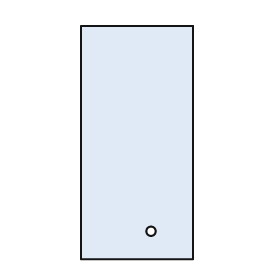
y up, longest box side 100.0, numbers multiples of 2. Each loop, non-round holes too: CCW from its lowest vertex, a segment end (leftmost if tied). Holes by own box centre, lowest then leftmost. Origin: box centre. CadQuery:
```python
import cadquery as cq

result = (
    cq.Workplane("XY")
    .moveTo(-24.0, -50.0)
    .lineTo(24.0, -50.0)
    .lineTo(24.0, 50.0)
    .lineTo(-24.0, 50.0)
    .close()
    .moveTo(6.0, -38.0)
    .circle(2.0)
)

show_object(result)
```